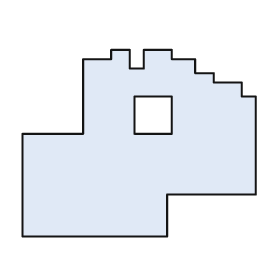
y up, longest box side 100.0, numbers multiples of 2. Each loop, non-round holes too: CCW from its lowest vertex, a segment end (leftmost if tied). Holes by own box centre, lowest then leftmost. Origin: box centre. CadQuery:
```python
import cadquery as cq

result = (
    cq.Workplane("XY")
    .moveTo(-50.0, -40.0)
    .lineTo(12.0, -40.0)
    .lineTo(12.0, -22.0)
    .lineTo(50.0, -22.0)
    .lineTo(50.0, 20.0)
    .lineTo(44.0, 20.0)
    .lineTo(44.0, 26.0)
    .lineTo(32.0, 26.0)
    .lineTo(32.0, 30.0)
    .lineTo(24.0, 30.0)
    .lineTo(24.0, 36.0)
    .lineTo(14.0, 36.0)
    .lineTo(14.0, 40.0)
    .lineTo(2.0, 40.0)
    .lineTo(2.0, 32.0)
    .lineTo(-4.0, 32.0)
    .lineTo(-4.0, 40.0)
    .lineTo(-12.0, 40.0)
    .lineTo(-12.0, 36.0)
    .lineTo(-24.0, 36.0)
    .lineTo(-24.0, 4.0)
    .lineTo(-50.0, 4.0)
    .close()
    .moveTo(-2.0, 4.0)
    .lineTo(14.0, 4.0)
    .lineTo(14.0, 20.0)
    .lineTo(-2.0, 20.0)
    .close()
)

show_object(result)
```